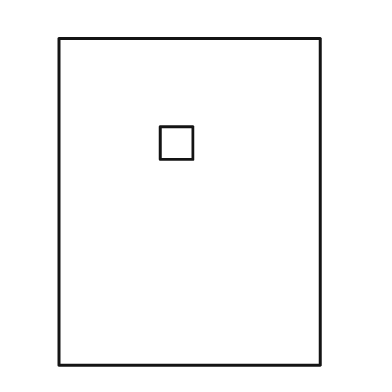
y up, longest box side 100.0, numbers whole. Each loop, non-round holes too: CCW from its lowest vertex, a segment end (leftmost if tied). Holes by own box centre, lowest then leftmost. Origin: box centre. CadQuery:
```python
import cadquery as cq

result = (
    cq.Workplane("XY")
    .moveTo(-40.0, -50.0)
    .lineTo(40.0, -50.0)
    .lineTo(40.0, 50.0)
    .lineTo(-40.0, 50.0)
    .close()
    .moveTo(-9.0, 13.0)
    .lineTo(1.0, 13.0)
    .lineTo(1.0, 23.0)
    .lineTo(-9.0, 23.0)
    .close()
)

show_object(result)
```